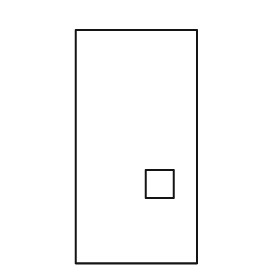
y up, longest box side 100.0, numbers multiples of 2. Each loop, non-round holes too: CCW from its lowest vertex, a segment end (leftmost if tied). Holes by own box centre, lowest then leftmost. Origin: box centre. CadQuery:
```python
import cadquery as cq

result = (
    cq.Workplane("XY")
    .moveTo(-26.0, -50.0)
    .lineTo(26.0, -50.0)
    .lineTo(26.0, 50.0)
    .lineTo(-26.0, 50.0)
    .close()
    .moveTo(4.0, -22.0)
    .lineTo(16.0, -22.0)
    .lineTo(16.0, -10.0)
    .lineTo(4.0, -10.0)
    .close()
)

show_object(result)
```